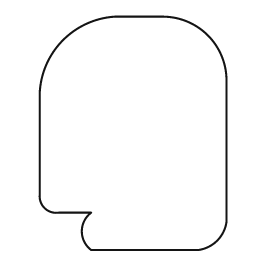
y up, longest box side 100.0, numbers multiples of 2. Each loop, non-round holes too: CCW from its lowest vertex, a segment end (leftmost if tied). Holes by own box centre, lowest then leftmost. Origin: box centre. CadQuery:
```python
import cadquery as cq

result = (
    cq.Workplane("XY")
    .moveTo(-18.0, -50.0)
    .lineTo(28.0, -50.0)
    .threePointArc((36.0, -46.0), (40.0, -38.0))
    .lineTo(40.0, 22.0)
    .threePointArc((32.0, 42.0), (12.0, 50.0))
    .lineTo(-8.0, 50.0)
    .threePointArc((-30.0, 40.0), (-40.0, 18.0))
    .lineTo(-40.0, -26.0)
    .threePointArc((-38.0, -32.0), (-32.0, -34.0))
    .lineTo(-18.0, -34.0)
    .threePointArc((-22.0, -42.0), (-18.0, -50.0))
    .close()
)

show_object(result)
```